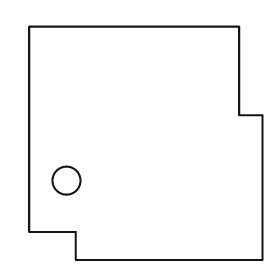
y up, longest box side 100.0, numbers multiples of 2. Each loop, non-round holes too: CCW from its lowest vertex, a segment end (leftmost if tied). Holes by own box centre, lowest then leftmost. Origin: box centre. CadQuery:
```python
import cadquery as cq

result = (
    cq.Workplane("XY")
    .moveTo(-30.0, -50.0)
    .lineTo(50.0, -50.0)
    .lineTo(50.0, 12.0)
    .lineTo(40.0, 12.0)
    .lineTo(40.0, 50.0)
    .lineTo(-50.0, 50.0)
    .lineTo(-50.0, -38.0)
    .lineTo(-30.0, -38.0)
    .close()
    .moveTo(-34.0, -16.0)
    .circle(6.0)
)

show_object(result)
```